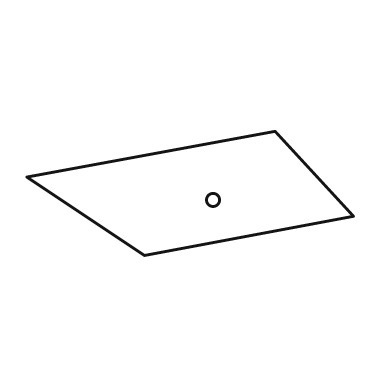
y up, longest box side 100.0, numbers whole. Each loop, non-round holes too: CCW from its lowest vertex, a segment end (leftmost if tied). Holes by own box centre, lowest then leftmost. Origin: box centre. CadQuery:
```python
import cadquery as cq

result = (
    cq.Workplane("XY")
    .moveTo(-14.0, -19.0)
    .lineTo(50.0, -7.0)
    .lineTo(26.0, 19.0)
    .lineTo(-50.0, 5.0)
    .close()
    .moveTo(7.0, -2.0)
    .circle(2.0)
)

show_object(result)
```